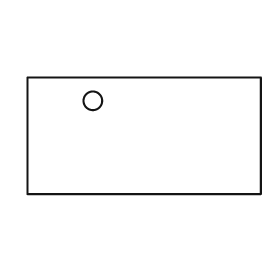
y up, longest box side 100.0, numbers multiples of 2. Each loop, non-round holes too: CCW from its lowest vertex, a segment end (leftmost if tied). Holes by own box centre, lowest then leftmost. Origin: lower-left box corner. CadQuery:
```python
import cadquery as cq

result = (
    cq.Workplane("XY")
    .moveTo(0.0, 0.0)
    .lineTo(100.0, 0.0)
    .lineTo(100.0, 50.0)
    .lineTo(0.0, 50.0)
    .close()
    .moveTo(28.0, 40.0)
    .circle(4.0)
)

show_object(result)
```